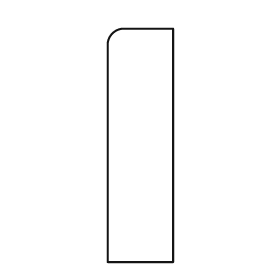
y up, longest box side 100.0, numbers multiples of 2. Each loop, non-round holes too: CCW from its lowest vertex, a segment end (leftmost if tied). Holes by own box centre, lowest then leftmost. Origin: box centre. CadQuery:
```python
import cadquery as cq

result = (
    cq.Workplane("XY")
    .moveTo(-14.0, -50.0)
    .lineTo(14.0, -50.0)
    .lineTo(14.0, 50.0)
    .lineTo(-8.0, 50.0)
    .threePointArc((-12.0, 48.0), (-14.0, 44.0))
    .close()
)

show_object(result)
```